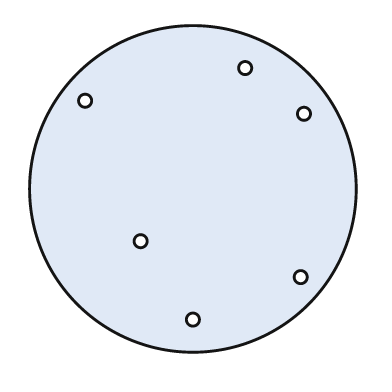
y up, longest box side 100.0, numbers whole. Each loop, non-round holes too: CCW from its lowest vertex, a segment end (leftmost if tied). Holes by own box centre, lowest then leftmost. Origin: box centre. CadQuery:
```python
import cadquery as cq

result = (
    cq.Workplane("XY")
    .moveTo(0.0, 0.0)
    .circle(50.0)
    .moveTo(0.0, -40.0)
    .circle(2.0)
    .moveTo(33.0, -27.0)
    .circle(2.0)
    .moveTo(-16.0, -16.0)
    .circle(2.0)
    .moveTo(34.0, 23.0)
    .circle(2.0)
    .moveTo(-33.0, 27.0)
    .circle(2.0)
    .moveTo(16.0, 37.0)
    .circle(2.0)
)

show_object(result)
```